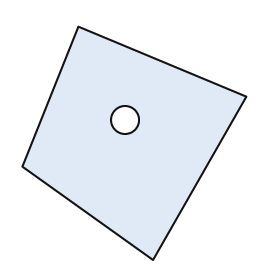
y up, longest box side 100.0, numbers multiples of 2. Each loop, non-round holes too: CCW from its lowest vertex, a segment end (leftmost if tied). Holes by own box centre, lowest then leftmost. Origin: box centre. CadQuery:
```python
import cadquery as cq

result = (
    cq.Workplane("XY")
    .moveTo(8.0, -50.0)
    .lineTo(48.0, 20.0)
    .lineTo(-24.0, 50.0)
    .lineTo(-48.0, -10.0)
    .close()
    .moveTo(-4.0, 10.0)
    .circle(6.0)
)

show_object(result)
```